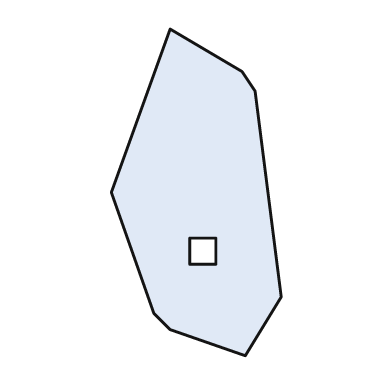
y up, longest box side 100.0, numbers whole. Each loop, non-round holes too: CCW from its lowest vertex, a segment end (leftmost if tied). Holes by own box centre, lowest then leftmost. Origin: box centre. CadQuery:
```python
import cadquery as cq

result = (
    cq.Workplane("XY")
    .moveTo(15.0, -50.0)
    .lineTo(26.0, -32.0)
    .lineTo(18.0, 31.0)
    .lineTo(14.0, 37.0)
    .lineTo(-8.0, 50.0)
    .lineTo(-26.0, 0.0)
    .lineTo(-13.0, -37.0)
    .lineTo(-8.0, -42.0)
    .close()
    .moveTo(-2.0, -22.0)
    .lineTo(6.0, -22.0)
    .lineTo(6.0, -14.0)
    .lineTo(-2.0, -14.0)
    .close()
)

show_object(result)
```